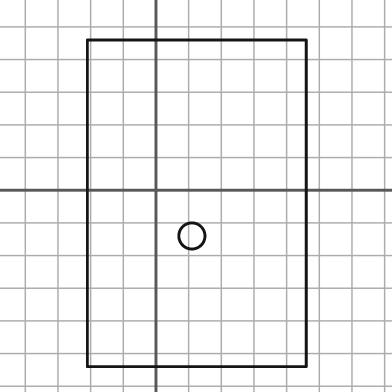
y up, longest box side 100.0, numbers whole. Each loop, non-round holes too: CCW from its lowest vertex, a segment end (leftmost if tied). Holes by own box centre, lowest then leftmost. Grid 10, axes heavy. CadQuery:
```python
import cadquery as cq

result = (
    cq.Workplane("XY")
    .moveTo(-21.0, -54.0)
    .lineTo(46.0, -54.0)
    .lineTo(46.0, 46.0)
    .lineTo(-21.0, 46.0)
    .close()
    .moveTo(11.0, -14.0)
    .circle(4.0)
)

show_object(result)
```